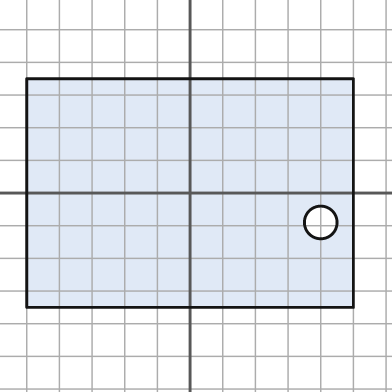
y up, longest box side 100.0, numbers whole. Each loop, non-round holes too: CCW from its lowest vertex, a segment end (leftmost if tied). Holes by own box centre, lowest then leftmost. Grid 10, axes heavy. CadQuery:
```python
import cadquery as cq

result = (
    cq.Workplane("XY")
    .moveTo(-50.0, -35.0)
    .lineTo(50.0, -35.0)
    .lineTo(50.0, 35.0)
    .lineTo(-50.0, 35.0)
    .close()
    .moveTo(40.0, -9.0)
    .circle(5.0)
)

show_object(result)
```